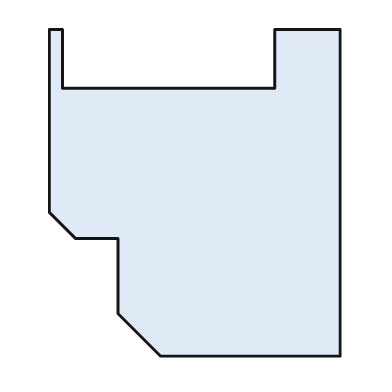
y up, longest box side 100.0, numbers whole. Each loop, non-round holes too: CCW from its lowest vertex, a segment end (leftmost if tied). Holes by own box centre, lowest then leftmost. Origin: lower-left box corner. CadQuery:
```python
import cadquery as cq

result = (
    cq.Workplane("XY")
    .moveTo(34.0, 0.0)
    .lineTo(89.0, 0.0)
    .lineTo(89.0, 100.0)
    .lineTo(69.0, 100.0)
    .lineTo(69.0, 82.0)
    .lineTo(4.0, 82.0)
    .lineTo(4.0, 100.0)
    .lineTo(0.0, 100.0)
    .lineTo(0.0, 44.0)
    .lineTo(8.0, 36.0)
    .lineTo(21.0, 36.0)
    .lineTo(21.0, 13.0)
    .close()
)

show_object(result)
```